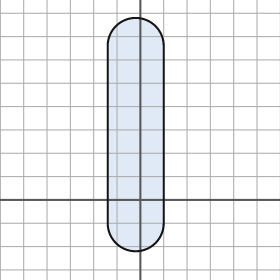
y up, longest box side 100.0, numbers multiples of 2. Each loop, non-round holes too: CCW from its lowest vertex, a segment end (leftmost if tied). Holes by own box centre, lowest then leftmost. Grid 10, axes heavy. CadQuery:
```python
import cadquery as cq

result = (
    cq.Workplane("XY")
    .moveTo(-14.0, -10.0)
    .threePointArc((-2.0, -22.0), (10.0, -10.0))
    .lineTo(10.0, 66.0)
    .threePointArc((-2.0, 78.0), (-14.0, 66.0))
    .close()
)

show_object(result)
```